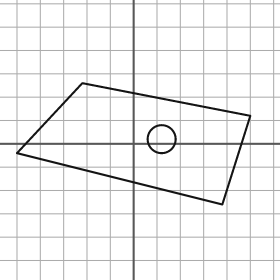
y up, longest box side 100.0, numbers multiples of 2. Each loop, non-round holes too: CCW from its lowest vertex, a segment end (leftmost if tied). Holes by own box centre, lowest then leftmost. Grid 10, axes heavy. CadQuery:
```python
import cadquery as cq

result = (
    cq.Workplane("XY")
    .moveTo(38.0, -26.0)
    .lineTo(50.0, 12.0)
    .lineTo(-22.0, 26.0)
    .lineTo(-50.0, -4.0)
    .close()
    .moveTo(12.0, 2.0)
    .circle(6.0)
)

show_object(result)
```